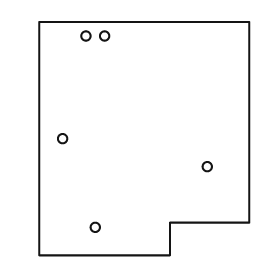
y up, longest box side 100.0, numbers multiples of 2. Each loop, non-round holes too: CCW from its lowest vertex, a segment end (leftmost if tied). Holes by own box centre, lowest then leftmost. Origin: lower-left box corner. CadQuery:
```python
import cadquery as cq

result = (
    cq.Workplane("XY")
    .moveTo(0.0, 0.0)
    .lineTo(56.0, 0.0)
    .lineTo(56.0, 14.0)
    .lineTo(90.0, 14.0)
    .lineTo(90.0, 100.0)
    .lineTo(0.0, 100.0)
    .close()
    .moveTo(24.0, 12.0)
    .circle(2.0)
    .moveTo(72.0, 38.0)
    .circle(2.0)
    .moveTo(10.0, 50.0)
    .circle(2.0)
    .moveTo(20.0, 94.0)
    .circle(2.0)
    .moveTo(28.0, 94.0)
    .circle(2.0)
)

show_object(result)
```